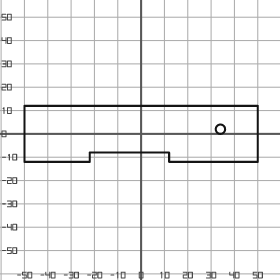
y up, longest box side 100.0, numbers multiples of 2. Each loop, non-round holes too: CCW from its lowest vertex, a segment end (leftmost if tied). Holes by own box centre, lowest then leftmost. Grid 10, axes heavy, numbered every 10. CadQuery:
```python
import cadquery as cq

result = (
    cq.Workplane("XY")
    .moveTo(-50.0, -12.0)
    .lineTo(-22.0, -12.0)
    .lineTo(-22.0, -8.0)
    .lineTo(12.0, -8.0)
    .lineTo(12.0, -12.0)
    .lineTo(50.0, -12.0)
    .lineTo(50.0, 12.0)
    .lineTo(-50.0, 12.0)
    .close()
    .moveTo(34.0, 2.0)
    .circle(2.0)
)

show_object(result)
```